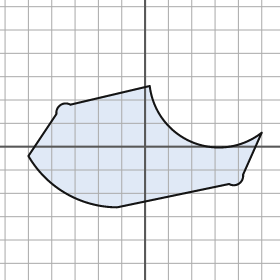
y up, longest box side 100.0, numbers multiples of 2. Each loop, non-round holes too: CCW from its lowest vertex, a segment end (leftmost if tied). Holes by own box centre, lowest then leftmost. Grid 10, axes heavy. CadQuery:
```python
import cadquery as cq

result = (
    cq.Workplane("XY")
    .moveTo(-12.0, -26.0)
    .lineTo(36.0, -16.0)
    .threePointArc((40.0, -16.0), (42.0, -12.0))
    .lineTo(50.0, 6.0)
    .threePointArc((20.0, 2.0), (2.0, 26.0))
    .lineTo(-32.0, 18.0)
    .threePointArc((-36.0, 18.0), (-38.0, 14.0))
    .lineTo(-50.0, -4.0)
    .threePointArc((-34.0, -20.0), (-12.0, -26.0))
    .close()
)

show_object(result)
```